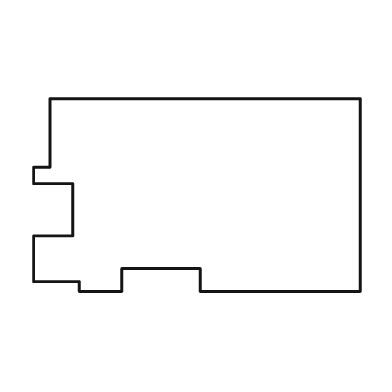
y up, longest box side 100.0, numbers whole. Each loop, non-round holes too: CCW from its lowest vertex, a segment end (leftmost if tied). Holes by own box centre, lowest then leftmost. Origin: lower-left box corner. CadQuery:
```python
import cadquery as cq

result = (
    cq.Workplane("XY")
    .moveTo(14.0, 0.0)
    .lineTo(27.0, 0.0)
    .lineTo(27.0, 7.0)
    .lineTo(51.0, 7.0)
    .lineTo(51.0, 0.0)
    .lineTo(100.0, 0.0)
    .lineTo(100.0, 59.0)
    .lineTo(5.0, 59.0)
    .lineTo(5.0, 38.0)
    .lineTo(0.0, 38.0)
    .lineTo(0.0, 33.0)
    .lineTo(12.0, 33.0)
    .lineTo(12.0, 17.0)
    .lineTo(0.0, 17.0)
    .lineTo(0.0, 3.0)
    .lineTo(14.0, 3.0)
    .close()
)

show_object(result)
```